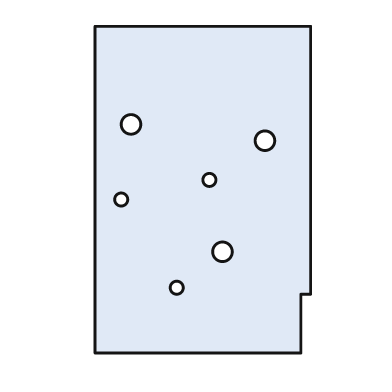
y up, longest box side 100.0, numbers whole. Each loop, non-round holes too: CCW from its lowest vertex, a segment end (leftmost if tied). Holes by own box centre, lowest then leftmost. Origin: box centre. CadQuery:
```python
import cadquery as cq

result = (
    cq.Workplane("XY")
    .moveTo(-33.0, -50.0)
    .lineTo(30.0, -50.0)
    .lineTo(30.0, -32.0)
    .lineTo(33.0, -32.0)
    .lineTo(33.0, 50.0)
    .lineTo(-33.0, 50.0)
    .close()
    .moveTo(-8.0, -30.0)
    .circle(2.0)
    .moveTo(6.0, -19.0)
    .circle(3.0)
    .moveTo(-25.0, -3.0)
    .circle(2.0)
    .moveTo(2.0, 3.0)
    .circle(2.0)
    .moveTo(19.0, 15.0)
    .circle(3.0)
    .moveTo(-22.0, 20.0)
    .circle(3.0)
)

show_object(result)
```